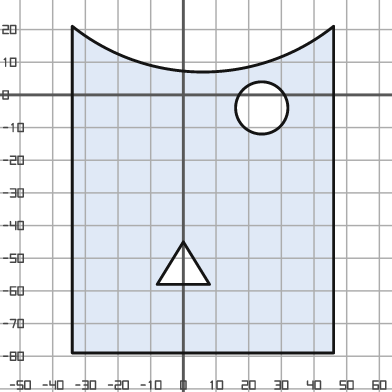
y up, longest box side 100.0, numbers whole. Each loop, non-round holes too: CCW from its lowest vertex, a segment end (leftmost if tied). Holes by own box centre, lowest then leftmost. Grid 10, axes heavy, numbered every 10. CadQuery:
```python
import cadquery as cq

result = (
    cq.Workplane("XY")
    .moveTo(-34.0, -79.0)
    .lineTo(46.0, -79.0)
    .lineTo(46.0, 21.0)
    .threePointArc((6.0, 7.0), (-34.0, 21.0))
    .close()
    .moveTo(-8.0, -58.0)
    .lineTo(8.0, -58.0)
    .lineTo(0.0, -45.0)
    .close()
    .moveTo(24.0, -4.0)
    .circle(8.0)
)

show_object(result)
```